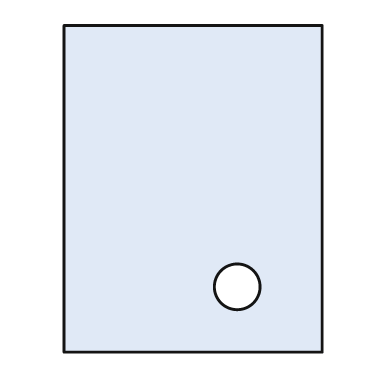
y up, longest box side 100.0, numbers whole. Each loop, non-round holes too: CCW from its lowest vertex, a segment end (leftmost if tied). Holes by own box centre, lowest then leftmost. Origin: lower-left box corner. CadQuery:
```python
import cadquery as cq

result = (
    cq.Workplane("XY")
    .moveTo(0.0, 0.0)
    .lineTo(79.0, 0.0)
    .lineTo(79.0, 100.0)
    .lineTo(0.0, 100.0)
    .close()
    .moveTo(53.0, 20.0)
    .circle(7.0)
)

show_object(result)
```